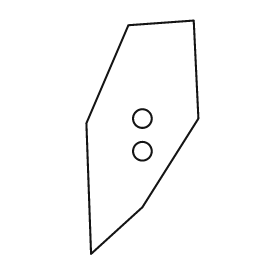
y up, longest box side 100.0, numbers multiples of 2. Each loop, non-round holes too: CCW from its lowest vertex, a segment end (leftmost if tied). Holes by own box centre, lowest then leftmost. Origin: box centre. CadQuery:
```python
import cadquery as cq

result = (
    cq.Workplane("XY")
    .moveTo(-22.0, -50.0)
    .lineTo(0.0, -30.0)
    .lineTo(24.0, 8.0)
    .lineTo(22.0, 50.0)
    .lineTo(-6.0, 48.0)
    .lineTo(-24.0, 6.0)
    .close()
    .moveTo(0.0, -6.0)
    .circle(4.0)
    .moveTo(0.0, 8.0)
    .circle(4.0)
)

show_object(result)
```